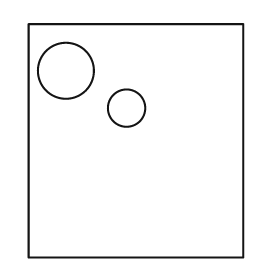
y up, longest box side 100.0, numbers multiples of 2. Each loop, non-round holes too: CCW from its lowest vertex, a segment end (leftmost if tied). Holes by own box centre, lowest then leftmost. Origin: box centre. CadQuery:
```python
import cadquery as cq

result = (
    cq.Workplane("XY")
    .moveTo(-46.0, -50.0)
    .lineTo(46.0, -50.0)
    .lineTo(46.0, 50.0)
    .lineTo(-46.0, 50.0)
    .close()
    .moveTo(-4.0, 14.0)
    .circle(8.0)
    .moveTo(-30.0, 30.0)
    .circle(12.0)
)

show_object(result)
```